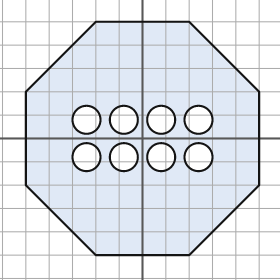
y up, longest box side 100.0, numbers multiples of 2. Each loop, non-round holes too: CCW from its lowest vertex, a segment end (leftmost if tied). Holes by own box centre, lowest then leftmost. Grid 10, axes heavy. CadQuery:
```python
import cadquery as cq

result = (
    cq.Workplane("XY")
    .moveTo(-20.0, -50.0)
    .lineTo(20.0, -50.0)
    .lineTo(50.0, -20.0)
    .lineTo(50.0, 20.0)
    .lineTo(20.0, 50.0)
    .lineTo(-20.0, 50.0)
    .lineTo(-50.0, 20.0)
    .lineTo(-50.0, -20.0)
    .close()
    .moveTo(-24.0, -8.0)
    .circle(6.0)
    .moveTo(-8.0, -8.0)
    .circle(6.0)
    .moveTo(8.0, -8.0)
    .circle(6.0)
    .moveTo(24.0, -8.0)
    .circle(6.0)
    .moveTo(-24.0, 8.0)
    .circle(6.0)
    .moveTo(-8.0, 8.0)
    .circle(6.0)
    .moveTo(8.0, 8.0)
    .circle(6.0)
    .moveTo(24.0, 8.0)
    .circle(6.0)
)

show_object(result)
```